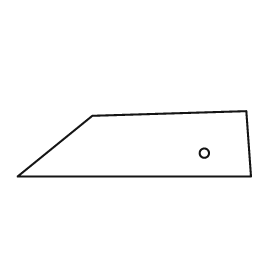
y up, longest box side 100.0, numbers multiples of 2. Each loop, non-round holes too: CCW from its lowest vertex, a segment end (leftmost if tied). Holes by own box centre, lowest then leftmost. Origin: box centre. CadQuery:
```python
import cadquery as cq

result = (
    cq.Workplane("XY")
    .moveTo(-50.0, -14.0)
    .lineTo(50.0, -14.0)
    .lineTo(48.0, 14.0)
    .lineTo(-18.0, 12.0)
    .close()
    .moveTo(30.0, -4.0)
    .circle(2.0)
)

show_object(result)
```